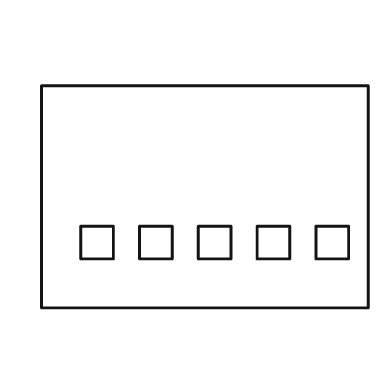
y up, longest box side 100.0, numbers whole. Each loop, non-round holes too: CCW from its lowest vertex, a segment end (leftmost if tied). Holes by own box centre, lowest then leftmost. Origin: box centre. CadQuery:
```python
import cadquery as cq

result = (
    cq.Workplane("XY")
    .moveTo(-50.0, -34.0)
    .lineTo(50.0, -34.0)
    .lineTo(50.0, 34.0)
    .lineTo(-50.0, 34.0)
    .close()
    .moveTo(-38.0, -19.0)
    .lineTo(-28.0, -19.0)
    .lineTo(-28.0, -9.0)
    .lineTo(-38.0, -9.0)
    .close()
    .moveTo(-20.0, -19.0)
    .lineTo(-10.0, -19.0)
    .lineTo(-10.0, -9.0)
    .lineTo(-20.0, -9.0)
    .close()
    .moveTo(-2.0, -19.0)
    .lineTo(8.0, -19.0)
    .lineTo(8.0, -9.0)
    .lineTo(-2.0, -9.0)
    .close()
    .moveTo(16.0, -19.0)
    .lineTo(26.0, -19.0)
    .lineTo(26.0, -9.0)
    .lineTo(16.0, -9.0)
    .close()
    .moveTo(34.0, -19.0)
    .lineTo(44.0, -19.0)
    .lineTo(44.0, -9.0)
    .lineTo(34.0, -9.0)
    .close()
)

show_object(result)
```